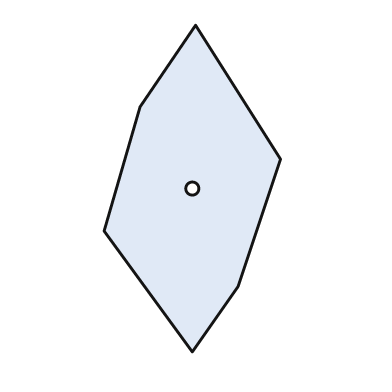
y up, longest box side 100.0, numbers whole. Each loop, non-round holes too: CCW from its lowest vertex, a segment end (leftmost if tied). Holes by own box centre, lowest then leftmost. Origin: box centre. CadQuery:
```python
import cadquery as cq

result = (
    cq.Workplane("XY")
    .moveTo(0.0, -50.0)
    .lineTo(14.0, -30.0)
    .lineTo(27.0, 9.0)
    .lineTo(1.0, 50.0)
    .lineTo(-16.0, 25.0)
    .lineTo(-27.0, -13.0)
    .close()
    .moveTo(0.0, 0.0)
    .circle(2.0)
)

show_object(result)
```